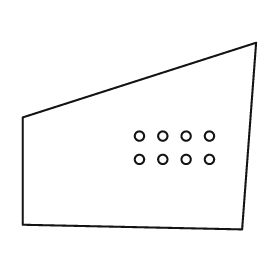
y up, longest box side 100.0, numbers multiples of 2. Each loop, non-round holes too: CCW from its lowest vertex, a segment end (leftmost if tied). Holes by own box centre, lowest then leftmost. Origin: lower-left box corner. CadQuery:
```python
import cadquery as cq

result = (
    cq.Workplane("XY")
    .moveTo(94.0, 0.0)
    .lineTo(100.0, 80.0)
    .lineTo(0.0, 48.0)
    .lineTo(0.0, 2.0)
    .close()
    .moveTo(50.0, 30.0)
    .circle(2.0)
    .moveTo(60.0, 30.0)
    .circle(2.0)
    .moveTo(70.0, 30.0)
    .circle(2.0)
    .moveTo(80.0, 30.0)
    .circle(2.0)
    .moveTo(50.0, 40.0)
    .circle(2.0)
    .moveTo(60.0, 40.0)
    .circle(2.0)
    .moveTo(70.0, 40.0)
    .circle(2.0)
    .moveTo(80.0, 40.0)
    .circle(2.0)
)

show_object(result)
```